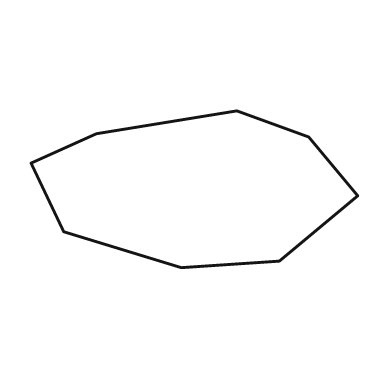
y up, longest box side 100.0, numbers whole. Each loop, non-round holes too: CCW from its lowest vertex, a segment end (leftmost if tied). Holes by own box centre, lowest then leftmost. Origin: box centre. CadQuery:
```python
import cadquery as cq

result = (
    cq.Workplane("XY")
    .moveTo(-4.0, -24.0)
    .lineTo(26.0, -22.0)
    .lineTo(50.0, -2.0)
    .lineTo(35.0, 16.0)
    .lineTo(13.0, 24.0)
    .lineTo(-30.0, 17.0)
    .lineTo(-50.0, 8.0)
    .lineTo(-40.0, -13.0)
    .close()
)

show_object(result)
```